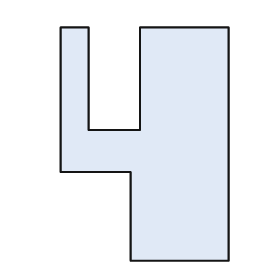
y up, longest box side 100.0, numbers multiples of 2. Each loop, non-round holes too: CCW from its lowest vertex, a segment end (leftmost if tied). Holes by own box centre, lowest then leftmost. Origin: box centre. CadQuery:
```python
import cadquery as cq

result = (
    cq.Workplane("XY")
    .moveTo(-6.0, -50.0)
    .lineTo(36.0, -50.0)
    .lineTo(36.0, 50.0)
    .lineTo(-2.0, 50.0)
    .lineTo(-2.0, 6.0)
    .lineTo(-24.0, 6.0)
    .lineTo(-24.0, 50.0)
    .lineTo(-36.0, 50.0)
    .lineTo(-36.0, -12.0)
    .lineTo(-6.0, -12.0)
    .close()
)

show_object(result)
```